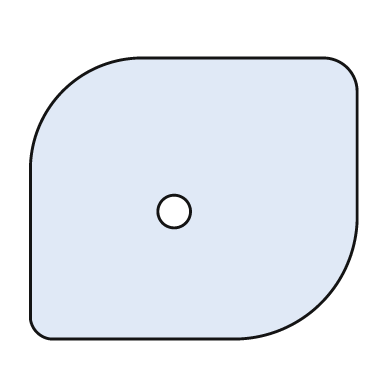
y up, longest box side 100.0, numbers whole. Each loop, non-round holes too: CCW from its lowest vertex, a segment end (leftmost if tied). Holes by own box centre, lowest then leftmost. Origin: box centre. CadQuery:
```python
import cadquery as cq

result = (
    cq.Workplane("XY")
    .moveTo(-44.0, -43.0)
    .lineTo(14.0, -43.0)
    .threePointArc((39.0, -32.0), (50.0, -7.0))
    .lineTo(50.0, 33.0)
    .threePointArc((47.0, 40.0), (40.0, 43.0))
    .lineTo(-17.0, 43.0)
    .threePointArc((-40.0, 33.0), (-50.0, 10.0))
    .lineTo(-50.0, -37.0)
    .threePointArc((-48.0, -41.0), (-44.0, -43.0))
    .close()
    .moveTo(-6.0, -4.0)
    .circle(5.0)
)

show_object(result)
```